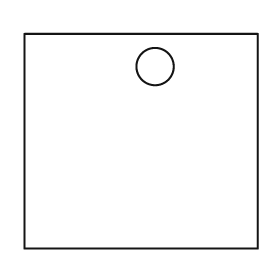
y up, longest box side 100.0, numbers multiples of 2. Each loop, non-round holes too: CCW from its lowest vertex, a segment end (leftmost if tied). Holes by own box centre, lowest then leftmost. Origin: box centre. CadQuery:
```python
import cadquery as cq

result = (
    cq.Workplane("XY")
    .moveTo(-50.0, -46.0)
    .lineTo(50.0, -46.0)
    .lineTo(50.0, 46.0)
    .lineTo(-50.0, 46.0)
    .close()
    .moveTo(6.0, 32.0)
    .circle(8.0)
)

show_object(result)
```